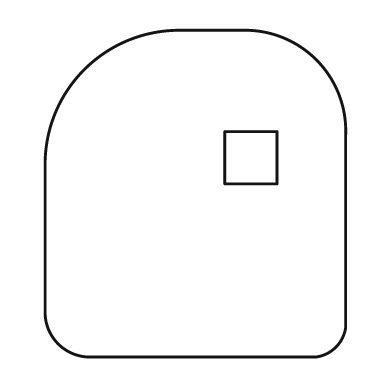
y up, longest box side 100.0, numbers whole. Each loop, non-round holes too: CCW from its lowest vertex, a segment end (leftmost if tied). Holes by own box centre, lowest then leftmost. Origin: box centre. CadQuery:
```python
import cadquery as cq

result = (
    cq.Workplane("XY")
    .moveTo(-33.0, -50.0)
    .lineTo(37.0, -50.0)
    .threePointArc((43.0, -47.0), (46.0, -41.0))
    .lineTo(46.0, 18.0)
    .threePointArc((37.0, 41.0), (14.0, 50.0))
    .lineTo(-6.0, 50.0)
    .threePointArc((-34.0, 38.0), (-46.0, 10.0))
    .lineTo(-46.0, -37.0)
    .threePointArc((-42.0, -46.0), (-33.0, -50.0))
    .close()
    .moveTo(9.0, 3.0)
    .lineTo(25.0, 3.0)
    .lineTo(25.0, 19.0)
    .lineTo(9.0, 19.0)
    .close()
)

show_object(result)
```